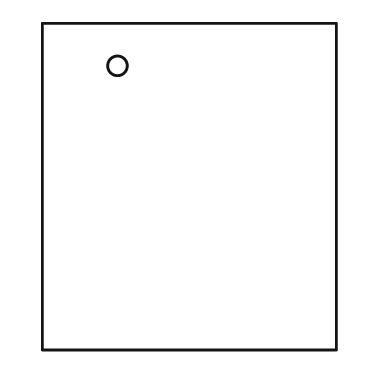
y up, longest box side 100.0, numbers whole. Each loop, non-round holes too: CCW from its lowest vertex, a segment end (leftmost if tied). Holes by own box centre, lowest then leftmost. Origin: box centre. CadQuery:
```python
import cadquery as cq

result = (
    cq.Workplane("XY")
    .moveTo(-45.0, -50.0)
    .lineTo(45.0, -50.0)
    .lineTo(45.0, 50.0)
    .lineTo(-45.0, 50.0)
    .close()
    .moveTo(-22.0, 37.0)
    .circle(3.0)
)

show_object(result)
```